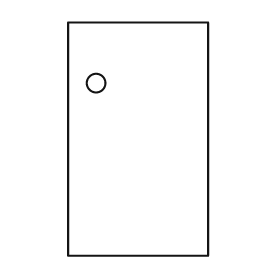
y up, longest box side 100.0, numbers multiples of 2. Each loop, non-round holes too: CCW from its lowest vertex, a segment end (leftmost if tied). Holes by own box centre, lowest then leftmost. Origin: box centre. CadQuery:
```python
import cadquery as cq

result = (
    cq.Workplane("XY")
    .moveTo(-30.0, -50.0)
    .lineTo(30.0, -50.0)
    .lineTo(30.0, 50.0)
    .lineTo(-30.0, 50.0)
    .close()
    .moveTo(-18.0, 24.0)
    .circle(4.0)
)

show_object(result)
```